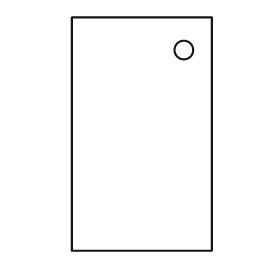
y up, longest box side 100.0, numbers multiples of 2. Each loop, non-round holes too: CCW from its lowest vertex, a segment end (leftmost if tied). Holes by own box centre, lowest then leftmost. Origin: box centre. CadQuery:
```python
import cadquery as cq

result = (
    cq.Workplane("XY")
    .moveTo(-30.0, -50.0)
    .lineTo(30.0, -50.0)
    .lineTo(30.0, 50.0)
    .lineTo(-30.0, 50.0)
    .close()
    .moveTo(18.0, 36.0)
    .circle(4.0)
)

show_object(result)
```